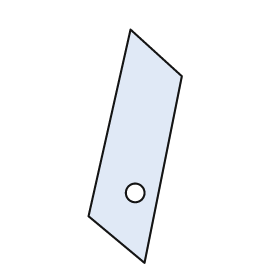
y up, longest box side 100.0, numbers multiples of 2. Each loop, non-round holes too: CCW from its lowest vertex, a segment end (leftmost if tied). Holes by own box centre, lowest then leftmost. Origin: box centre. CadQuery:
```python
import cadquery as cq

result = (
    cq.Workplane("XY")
    .moveTo(4.0, -50.0)
    .lineTo(20.0, 30.0)
    .lineTo(-2.0, 50.0)
    .lineTo(-20.0, -30.0)
    .close()
    .moveTo(0.0, -20.0)
    .circle(4.0)
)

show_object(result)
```